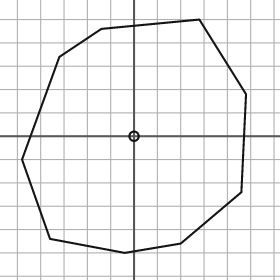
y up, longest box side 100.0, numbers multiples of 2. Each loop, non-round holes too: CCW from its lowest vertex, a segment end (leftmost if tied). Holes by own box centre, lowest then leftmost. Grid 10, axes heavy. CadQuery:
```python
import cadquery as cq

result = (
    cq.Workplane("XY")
    .moveTo(-4.0, -50.0)
    .lineTo(20.0, -46.0)
    .lineTo(46.0, -24.0)
    .lineTo(48.0, 18.0)
    .lineTo(28.0, 50.0)
    .lineTo(-14.0, 46.0)
    .lineTo(-32.0, 34.0)
    .lineTo(-48.0, -10.0)
    .lineTo(-36.0, -44.0)
    .close()
    .moveTo(0.0, 0.0)
    .circle(2.0)
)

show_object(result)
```